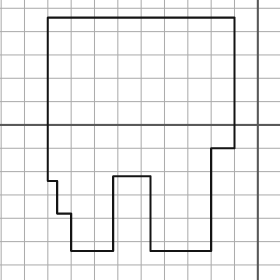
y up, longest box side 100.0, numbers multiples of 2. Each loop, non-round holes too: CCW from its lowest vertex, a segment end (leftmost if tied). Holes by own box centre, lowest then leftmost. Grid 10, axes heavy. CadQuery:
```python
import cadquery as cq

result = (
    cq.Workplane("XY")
    .moveTo(-80.0, -54.0)
    .lineTo(-62.0, -54.0)
    .lineTo(-62.0, -22.0)
    .lineTo(-46.0, -22.0)
    .lineTo(-46.0, -54.0)
    .lineTo(-20.0, -54.0)
    .lineTo(-20.0, -10.0)
    .lineTo(-10.0, -10.0)
    .lineTo(-10.0, 46.0)
    .lineTo(-90.0, 46.0)
    .lineTo(-90.0, -24.0)
    .lineTo(-86.0, -24.0)
    .lineTo(-86.0, -38.0)
    .lineTo(-80.0, -38.0)
    .close()
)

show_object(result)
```